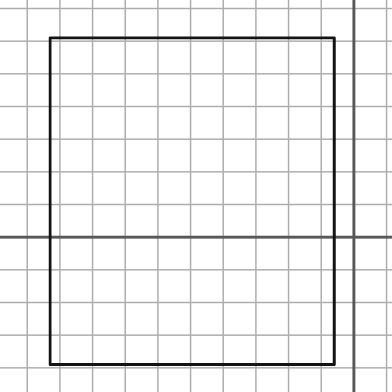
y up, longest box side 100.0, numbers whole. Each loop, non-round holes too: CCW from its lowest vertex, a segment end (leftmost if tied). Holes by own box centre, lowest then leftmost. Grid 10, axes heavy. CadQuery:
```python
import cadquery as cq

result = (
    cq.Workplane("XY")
    .moveTo(-93.0, -39.0)
    .lineTo(-6.0, -39.0)
    .lineTo(-6.0, 61.0)
    .lineTo(-93.0, 61.0)
    .close()
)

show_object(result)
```